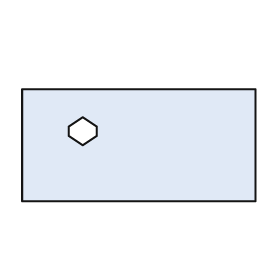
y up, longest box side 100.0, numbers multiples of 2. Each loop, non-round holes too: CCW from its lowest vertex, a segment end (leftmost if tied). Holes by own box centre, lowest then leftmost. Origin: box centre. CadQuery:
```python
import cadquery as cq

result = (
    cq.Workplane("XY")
    .moveTo(-50.0, -24.0)
    .lineTo(50.0, -24.0)
    .lineTo(50.0, 24.0)
    .lineTo(-50.0, 24.0)
    .close()
    .moveTo(-24.0, 0.0)
    .lineTo(-18.0, 4.0)
    .lineTo(-18.0, 8.0)
    .lineTo(-24.0, 12.0)
    .lineTo(-30.0, 8.0)
    .lineTo(-30.0, 4.0)
    .close()
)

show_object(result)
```